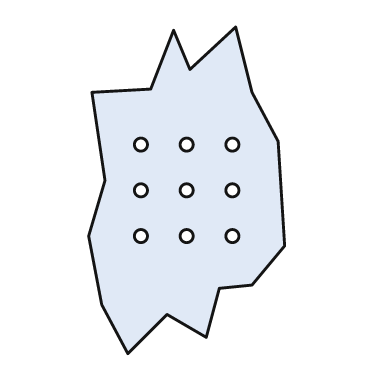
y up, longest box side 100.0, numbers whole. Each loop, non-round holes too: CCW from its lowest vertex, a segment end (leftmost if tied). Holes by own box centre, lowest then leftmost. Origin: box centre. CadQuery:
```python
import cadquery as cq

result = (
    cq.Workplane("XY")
    .moveTo(-18.0, -50.0)
    .lineTo(-6.0, -38.0)
    .lineTo(6.0, -45.0)
    .lineTo(10.0, -30.0)
    .lineTo(20.0, -29.0)
    .lineTo(30.0, -17.0)
    .lineTo(28.0, 15.0)
    .lineTo(20.0, 30.0)
    .lineTo(15.0, 50.0)
    .lineTo(1.0, 37.0)
    .lineTo(-4.0, 49.0)
    .lineTo(-11.0, 31.0)
    .lineTo(-29.0, 30.0)
    .lineTo(-25.0, 3.0)
    .lineTo(-30.0, -14.0)
    .lineTo(-26.0, -35.0)
    .close()
    .moveTo(-14.0, -14.0)
    .circle(2.0)
    .moveTo(0.0, -14.0)
    .circle(2.0)
    .moveTo(14.0, -14.0)
    .circle(2.0)
    .moveTo(-14.0, 0.0)
    .circle(2.0)
    .moveTo(0.0, 0.0)
    .circle(2.0)
    .moveTo(14.0, 0.0)
    .circle(2.0)
    .moveTo(-14.0, 14.0)
    .circle(2.0)
    .moveTo(0.0, 14.0)
    .circle(2.0)
    .moveTo(14.0, 14.0)
    .circle(2.0)
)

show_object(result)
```